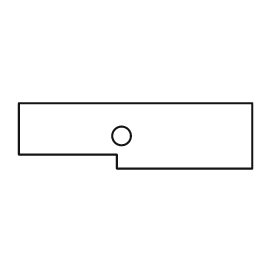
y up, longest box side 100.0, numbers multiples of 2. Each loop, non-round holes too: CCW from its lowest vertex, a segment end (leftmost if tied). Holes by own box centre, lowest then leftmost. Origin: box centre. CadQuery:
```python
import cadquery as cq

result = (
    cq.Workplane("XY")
    .moveTo(-8.0, -14.0)
    .lineTo(50.0, -14.0)
    .lineTo(50.0, 14.0)
    .lineTo(-50.0, 14.0)
    .lineTo(-50.0, -8.0)
    .lineTo(-8.0, -8.0)
    .close()
    .moveTo(-6.0, 0.0)
    .circle(4.0)
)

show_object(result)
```